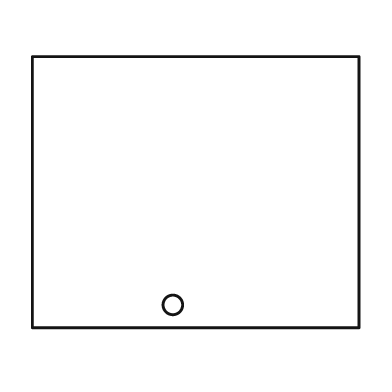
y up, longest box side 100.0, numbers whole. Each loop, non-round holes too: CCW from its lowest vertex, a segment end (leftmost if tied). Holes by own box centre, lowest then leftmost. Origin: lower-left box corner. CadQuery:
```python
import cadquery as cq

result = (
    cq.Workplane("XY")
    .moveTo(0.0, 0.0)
    .lineTo(100.0, 0.0)
    .lineTo(100.0, 83.0)
    .lineTo(0.0, 83.0)
    .close()
    .moveTo(43.0, 7.0)
    .circle(3.0)
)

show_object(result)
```